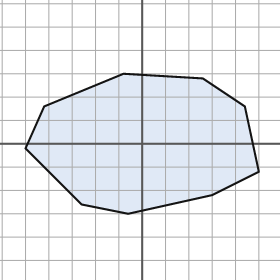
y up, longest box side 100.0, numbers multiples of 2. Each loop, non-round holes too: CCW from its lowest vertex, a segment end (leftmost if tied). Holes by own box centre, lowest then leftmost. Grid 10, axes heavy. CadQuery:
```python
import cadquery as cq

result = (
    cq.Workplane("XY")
    .moveTo(-6.0, -30.0)
    .lineTo(30.0, -22.0)
    .lineTo(50.0, -12.0)
    .lineTo(44.0, 16.0)
    .lineTo(26.0, 28.0)
    .lineTo(-8.0, 30.0)
    .lineTo(-42.0, 16.0)
    .lineTo(-50.0, -2.0)
    .lineTo(-26.0, -26.0)
    .close()
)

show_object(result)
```